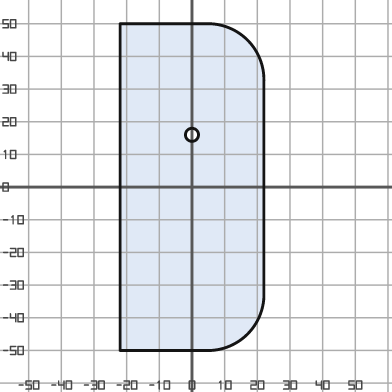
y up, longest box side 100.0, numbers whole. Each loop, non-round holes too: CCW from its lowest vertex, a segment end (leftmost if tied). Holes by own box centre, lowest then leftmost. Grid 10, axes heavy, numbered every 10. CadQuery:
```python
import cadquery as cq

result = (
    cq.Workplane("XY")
    .moveTo(-22.0, -50.0)
    .lineTo(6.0, -50.0)
    .threePointArc((17.0, -45.0), (22.0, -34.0))
    .lineTo(22.0, 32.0)
    .threePointArc((17.0, 45.0), (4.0, 50.0))
    .lineTo(-22.0, 50.0)
    .close()
    .moveTo(0.0, 16.0)
    .circle(2.0)
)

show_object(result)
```